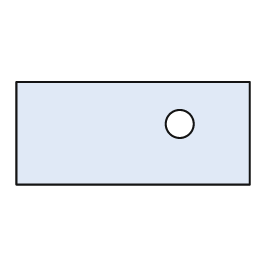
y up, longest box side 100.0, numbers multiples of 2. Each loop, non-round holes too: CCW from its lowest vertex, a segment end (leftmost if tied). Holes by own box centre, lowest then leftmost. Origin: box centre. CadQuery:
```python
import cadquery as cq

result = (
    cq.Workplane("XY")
    .moveTo(-50.0, -22.0)
    .lineTo(50.0, -22.0)
    .lineTo(50.0, 22.0)
    .lineTo(-50.0, 22.0)
    .close()
    .moveTo(20.0, 4.0)
    .circle(6.0)
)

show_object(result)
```